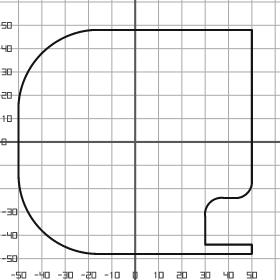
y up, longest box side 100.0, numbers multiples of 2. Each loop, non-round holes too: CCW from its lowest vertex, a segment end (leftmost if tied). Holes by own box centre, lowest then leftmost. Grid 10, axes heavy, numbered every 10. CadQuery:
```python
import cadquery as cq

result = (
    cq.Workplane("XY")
    .moveTo(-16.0, -48.0)
    .lineTo(50.0, -48.0)
    .lineTo(50.0, -44.0)
    .lineTo(30.0, -44.0)
    .lineTo(30.0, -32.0)
    .threePointArc((32.0, -26.0), (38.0, -24.0))
    .lineTo(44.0, -24.0)
    .threePointArc((48.0, -22.0), (50.0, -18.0))
    .lineTo(50.0, 48.0)
    .lineTo(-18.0, 48.0)
    .threePointArc((-40.0, 38.0), (-50.0, 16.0))
    .lineTo(-50.0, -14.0)
    .threePointArc((-40.0, -38.0), (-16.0, -48.0))
    .close()
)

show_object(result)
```